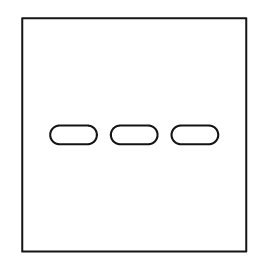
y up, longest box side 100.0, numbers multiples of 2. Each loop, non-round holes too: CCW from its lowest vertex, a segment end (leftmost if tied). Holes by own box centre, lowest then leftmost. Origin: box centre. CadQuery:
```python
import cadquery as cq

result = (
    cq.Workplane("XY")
    .moveTo(-48.0, -50.0)
    .lineTo(48.0, -50.0)
    .lineTo(48.0, 50.0)
    .lineTo(-48.0, 50.0)
    .close()
    .moveTo(-32.0, -4.0)
    .lineTo(-20.0, -4.0)
    .threePointArc((-16.0, 0.0), (-20.0, 4.0))
    .lineTo(-32.0, 4.0)
    .threePointArc((-36.0, 0.0), (-32.0, -4.0))
    .close()
    .moveTo(-6.0, -4.0)
    .lineTo(6.0, -4.0)
    .threePointArc((10.0, 0.0), (6.0, 4.0))
    .lineTo(-6.0, 4.0)
    .threePointArc((-10.0, 0.0), (-6.0, -4.0))
    .close()
    .moveTo(20.0, -4.0)
    .lineTo(32.0, -4.0)
    .threePointArc((36.0, 0.0), (32.0, 4.0))
    .lineTo(20.0, 4.0)
    .threePointArc((16.0, 0.0), (20.0, -4.0))
    .close()
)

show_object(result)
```